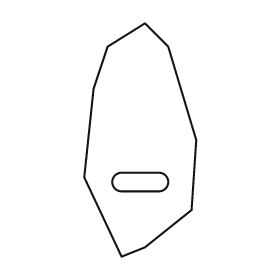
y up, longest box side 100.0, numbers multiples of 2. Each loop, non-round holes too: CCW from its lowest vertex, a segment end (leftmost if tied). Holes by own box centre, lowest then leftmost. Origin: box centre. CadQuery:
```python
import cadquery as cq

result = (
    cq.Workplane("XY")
    .moveTo(-8.0, -50.0)
    .lineTo(2.0, -46.0)
    .lineTo(22.0, -30.0)
    .lineTo(24.0, 0.0)
    .lineTo(12.0, 40.0)
    .lineTo(2.0, 50.0)
    .lineTo(-14.0, 40.0)
    .lineTo(-20.0, 22.0)
    .lineTo(-24.0, -16.0)
    .close()
    .moveTo(-8.0, -22.0)
    .lineTo(8.0, -22.0)
    .threePointArc((12.0, -18.0), (8.0, -14.0))
    .lineTo(-8.0, -14.0)
    .threePointArc((-12.0, -18.0), (-8.0, -22.0))
    .close()
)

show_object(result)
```